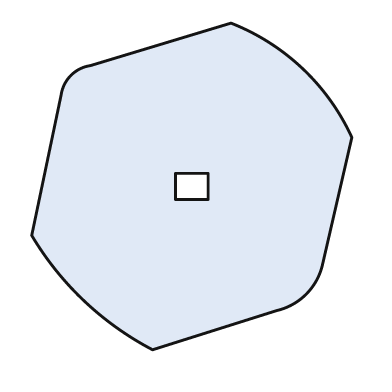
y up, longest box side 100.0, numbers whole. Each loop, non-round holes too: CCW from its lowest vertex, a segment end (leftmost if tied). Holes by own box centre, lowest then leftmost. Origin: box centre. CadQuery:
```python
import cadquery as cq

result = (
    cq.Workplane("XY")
    .moveTo(-12.0, -50.0)
    .lineTo(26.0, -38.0)
    .threePointArc((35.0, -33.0), (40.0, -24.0))
    .lineTo(49.0, 15.0)
    .threePointArc((34.0, 36.0), (12.0, 50.0))
    .lineTo(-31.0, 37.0)
    .threePointArc((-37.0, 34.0), (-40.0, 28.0))
    .lineTo(-49.0, -15.0)
    .threePointArc((-33.0, -35.0), (-12.0, -50.0))
    .close()
    .moveTo(-5.0, -4.0)
    .lineTo(5.0, -4.0)
    .lineTo(5.0, 4.0)
    .lineTo(-5.0, 4.0)
    .close()
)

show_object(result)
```